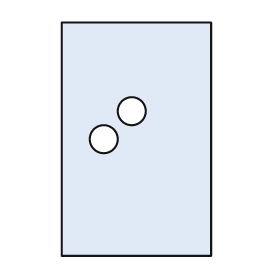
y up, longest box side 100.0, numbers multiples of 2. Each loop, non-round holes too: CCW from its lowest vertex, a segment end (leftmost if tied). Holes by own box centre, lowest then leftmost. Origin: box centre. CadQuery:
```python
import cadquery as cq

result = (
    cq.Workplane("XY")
    .moveTo(-32.0, -50.0)
    .lineTo(32.0, -50.0)
    .lineTo(32.0, 50.0)
    .lineTo(-32.0, 50.0)
    .close()
    .moveTo(-14.0, 0.0)
    .circle(6.0)
    .moveTo(-2.0, 12.0)
    .circle(6.0)
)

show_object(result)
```